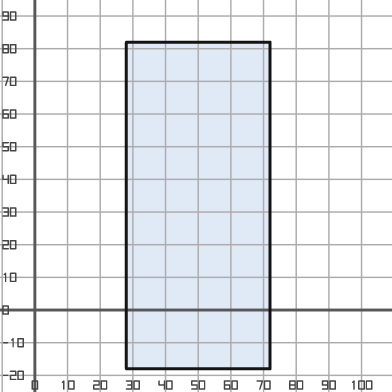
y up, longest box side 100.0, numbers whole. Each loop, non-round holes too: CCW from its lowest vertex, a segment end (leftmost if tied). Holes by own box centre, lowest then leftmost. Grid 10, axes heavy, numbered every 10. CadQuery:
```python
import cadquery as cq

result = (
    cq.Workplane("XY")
    .moveTo(28.0, -18.0)
    .lineTo(72.0, -18.0)
    .lineTo(72.0, 82.0)
    .lineTo(28.0, 82.0)
    .close()
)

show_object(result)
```